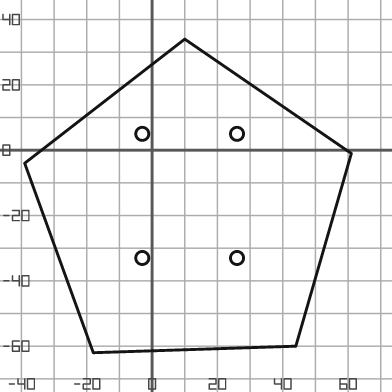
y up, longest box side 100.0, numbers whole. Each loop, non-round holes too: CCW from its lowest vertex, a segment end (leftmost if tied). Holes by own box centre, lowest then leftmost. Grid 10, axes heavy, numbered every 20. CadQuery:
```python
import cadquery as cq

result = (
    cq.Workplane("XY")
    .moveTo(-18.0, -62.0)
    .lineTo(44.0, -60.0)
    .lineTo(61.0, -1.0)
    .lineTo(10.0, 34.0)
    .lineTo(-39.0, -4.0)
    .close()
    .moveTo(-3.0, -33.0)
    .circle(2.0)
    .moveTo(26.0, -33.0)
    .circle(2.0)
    .moveTo(-3.0, 5.0)
    .circle(2.0)
    .moveTo(26.0, 5.0)
    .circle(2.0)
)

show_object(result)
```